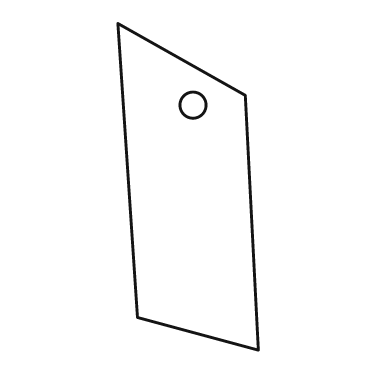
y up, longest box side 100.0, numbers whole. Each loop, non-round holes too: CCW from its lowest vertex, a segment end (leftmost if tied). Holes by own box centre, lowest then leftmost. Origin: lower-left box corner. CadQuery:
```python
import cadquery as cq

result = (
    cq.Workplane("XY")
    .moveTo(43.0, 0.0)
    .lineTo(39.0, 78.0)
    .lineTo(0.0, 100.0)
    .lineTo(6.0, 10.0)
    .close()
    .moveTo(23.0, 75.0)
    .circle(4.0)
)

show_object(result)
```